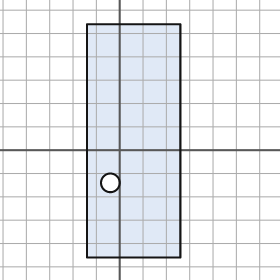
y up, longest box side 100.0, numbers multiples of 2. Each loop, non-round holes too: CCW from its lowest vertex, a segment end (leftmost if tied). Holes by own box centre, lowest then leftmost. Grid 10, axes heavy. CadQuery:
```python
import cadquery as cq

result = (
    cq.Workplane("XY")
    .moveTo(-14.0, -46.0)
    .lineTo(26.0, -46.0)
    .lineTo(26.0, 54.0)
    .lineTo(-14.0, 54.0)
    .close()
    .moveTo(-4.0, -14.0)
    .circle(4.0)
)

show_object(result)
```